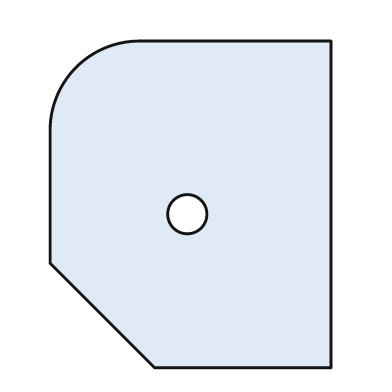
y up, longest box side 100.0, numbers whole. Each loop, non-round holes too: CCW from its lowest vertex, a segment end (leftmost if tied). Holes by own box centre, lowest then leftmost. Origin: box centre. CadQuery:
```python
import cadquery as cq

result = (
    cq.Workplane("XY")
    .moveTo(-11.0, -50.0)
    .lineTo(43.0, -50.0)
    .lineTo(43.0, 50.0)
    .lineTo(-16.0, 50.0)
    .threePointArc((-35.0, 42.0), (-43.0, 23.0))
    .lineTo(-43.0, -18.0)
    .close()
    .moveTo(-1.0, -3.0)
    .circle(6.0)
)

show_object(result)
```